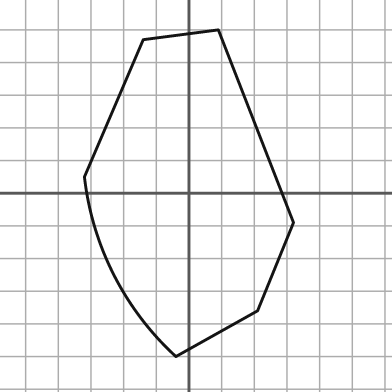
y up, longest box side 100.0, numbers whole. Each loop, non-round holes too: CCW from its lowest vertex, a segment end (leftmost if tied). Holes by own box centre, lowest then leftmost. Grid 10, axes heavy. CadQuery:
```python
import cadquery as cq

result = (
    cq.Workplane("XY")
    .moveTo(-4.0, -50.0)
    .lineTo(21.0, -36.0)
    .lineTo(32.0, -9.0)
    .lineTo(9.0, 50.0)
    .lineTo(-14.0, 47.0)
    .lineTo(-32.0, 5.0)
    .threePointArc((-23.0, -25.0), (-4.0, -50.0))
    .close()
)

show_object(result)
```